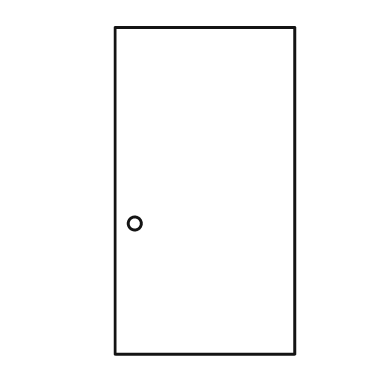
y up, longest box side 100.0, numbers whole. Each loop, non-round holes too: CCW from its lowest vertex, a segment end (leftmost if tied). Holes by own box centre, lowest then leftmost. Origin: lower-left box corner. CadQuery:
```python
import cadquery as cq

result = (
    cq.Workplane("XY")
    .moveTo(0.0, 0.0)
    .lineTo(55.0, 0.0)
    .lineTo(55.0, 100.0)
    .lineTo(0.0, 100.0)
    .close()
    .moveTo(6.0, 40.0)
    .circle(2.0)
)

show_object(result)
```